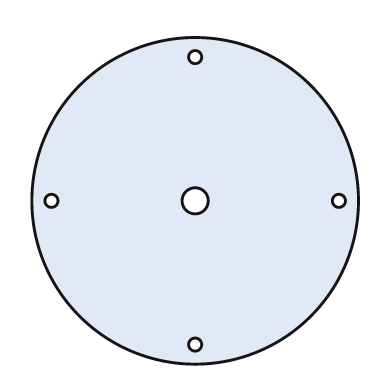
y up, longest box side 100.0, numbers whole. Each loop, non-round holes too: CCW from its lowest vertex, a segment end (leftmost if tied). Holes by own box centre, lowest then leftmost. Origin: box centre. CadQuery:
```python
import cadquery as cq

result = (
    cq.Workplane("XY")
    .moveTo(0.0, 0.0)
    .circle(50.0)
    .moveTo(0.0, -44.0)
    .circle(2.0)
    .moveTo(-44.0, 0.0)
    .circle(2.0)
    .moveTo(0.0, 0.0)
    .circle(4.0)
    .moveTo(44.0, 0.0)
    .circle(2.0)
    .moveTo(0.0, 44.0)
    .circle(2.0)
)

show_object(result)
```